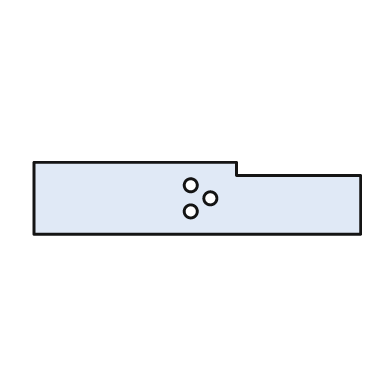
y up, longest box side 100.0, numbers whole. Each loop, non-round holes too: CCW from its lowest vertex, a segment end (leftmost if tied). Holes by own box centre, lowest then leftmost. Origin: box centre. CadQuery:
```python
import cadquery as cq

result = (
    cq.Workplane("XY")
    .moveTo(-50.0, -11.0)
    .lineTo(50.0, -11.0)
    .lineTo(50.0, 7.0)
    .lineTo(12.0, 7.0)
    .lineTo(12.0, 11.0)
    .lineTo(-50.0, 11.0)
    .close()
    .moveTo(-2.0, -4.0)
    .circle(2.0)
    .moveTo(4.0, 0.0)
    .circle(2.0)
    .moveTo(-2.0, 4.0)
    .circle(2.0)
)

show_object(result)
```